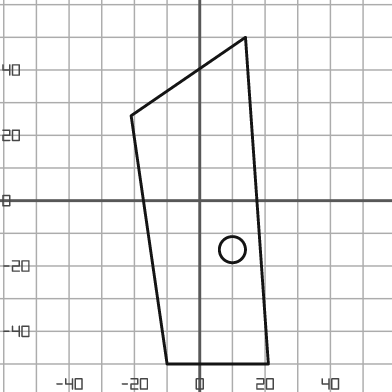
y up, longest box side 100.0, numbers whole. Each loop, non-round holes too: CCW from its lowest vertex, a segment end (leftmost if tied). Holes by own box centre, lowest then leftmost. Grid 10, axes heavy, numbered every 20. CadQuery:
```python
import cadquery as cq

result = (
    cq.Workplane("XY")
    .moveTo(-10.0, -50.0)
    .lineTo(21.0, -50.0)
    .lineTo(14.0, 50.0)
    .lineTo(-21.0, 26.0)
    .close()
    .moveTo(10.0, -15.0)
    .circle(4.0)
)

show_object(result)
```